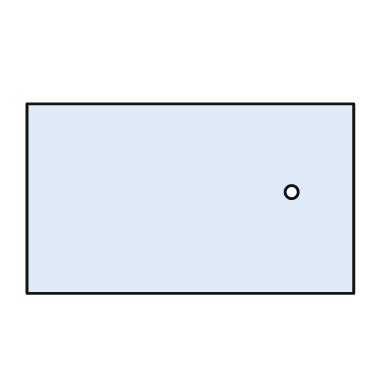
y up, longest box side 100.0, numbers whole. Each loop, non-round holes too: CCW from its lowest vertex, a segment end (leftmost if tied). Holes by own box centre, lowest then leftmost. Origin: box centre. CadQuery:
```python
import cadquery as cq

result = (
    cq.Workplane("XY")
    .moveTo(-50.0, -29.0)
    .lineTo(50.0, -29.0)
    .lineTo(50.0, 29.0)
    .lineTo(-50.0, 29.0)
    .close()
    .moveTo(31.0, 2.0)
    .circle(2.0)
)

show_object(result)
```